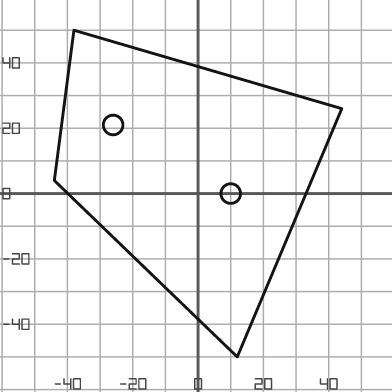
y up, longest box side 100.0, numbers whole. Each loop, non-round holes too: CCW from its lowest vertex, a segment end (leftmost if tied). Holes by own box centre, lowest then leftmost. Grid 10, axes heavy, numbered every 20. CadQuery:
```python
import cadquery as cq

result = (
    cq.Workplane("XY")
    .moveTo(12.0, -50.0)
    .lineTo(44.0, 26.0)
    .lineTo(-38.0, 50.0)
    .lineTo(-44.0, 4.0)
    .close()
    .moveTo(10.0, 0.0)
    .circle(3.0)
    .moveTo(-26.0, 21.0)
    .circle(3.0)
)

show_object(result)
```